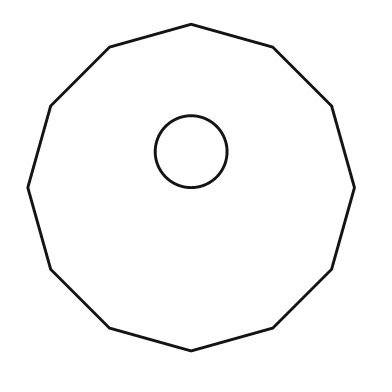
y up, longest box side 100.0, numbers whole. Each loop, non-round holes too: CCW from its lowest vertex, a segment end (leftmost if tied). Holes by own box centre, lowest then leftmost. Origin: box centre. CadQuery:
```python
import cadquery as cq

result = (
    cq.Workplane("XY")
    .moveTo(0.0, -50.0)
    .lineTo(25.0, -43.0)
    .lineTo(43.0, -25.0)
    .lineTo(50.0, 0.0)
    .lineTo(43.0, 25.0)
    .lineTo(25.0, 43.0)
    .lineTo(0.0, 50.0)
    .lineTo(-25.0, 43.0)
    .lineTo(-43.0, 25.0)
    .lineTo(-50.0, 0.0)
    .lineTo(-43.0, -25.0)
    .lineTo(-25.0, -43.0)
    .close()
    .moveTo(0.0, 11.0)
    .circle(11.0)
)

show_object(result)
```